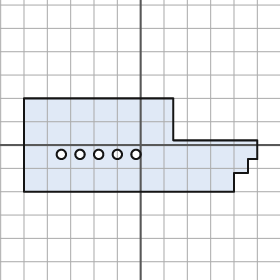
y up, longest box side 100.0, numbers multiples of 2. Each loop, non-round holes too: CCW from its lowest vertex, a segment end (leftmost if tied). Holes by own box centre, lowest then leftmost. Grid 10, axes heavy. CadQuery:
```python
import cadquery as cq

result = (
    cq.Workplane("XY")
    .moveTo(-50.0, -20.0)
    .lineTo(40.0, -20.0)
    .lineTo(40.0, -12.0)
    .lineTo(46.0, -12.0)
    .lineTo(46.0, -6.0)
    .lineTo(50.0, -6.0)
    .lineTo(50.0, 2.0)
    .lineTo(14.0, 2.0)
    .lineTo(14.0, 20.0)
    .lineTo(-50.0, 20.0)
    .close()
    .moveTo(-34.0, -4.0)
    .circle(2.0)
    .moveTo(-26.0, -4.0)
    .circle(2.0)
    .moveTo(-18.0, -4.0)
    .circle(2.0)
    .moveTo(-10.0, -4.0)
    .circle(2.0)
    .moveTo(-2.0, -4.0)
    .circle(2.0)
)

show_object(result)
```